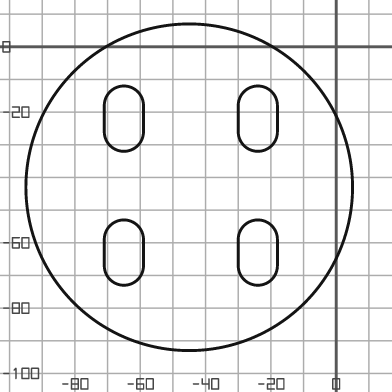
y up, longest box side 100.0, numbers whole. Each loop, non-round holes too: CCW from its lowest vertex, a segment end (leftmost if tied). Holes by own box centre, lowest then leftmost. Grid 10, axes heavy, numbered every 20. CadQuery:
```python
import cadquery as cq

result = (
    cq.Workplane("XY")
    .moveTo(-45.0, -43.0)
    .circle(50.0)
    .moveTo(-71.0, -67.0)
    .threePointArc((-65.0, -73.0), (-59.0, -67.0))
    .lineTo(-59.0, -59.0)
    .threePointArc((-65.0, -53.0), (-71.0, -59.0))
    .close()
    .moveTo(-30.0, -67.0)
    .threePointArc((-24.0, -73.0), (-18.0, -67.0))
    .lineTo(-18.0, -59.0)
    .threePointArc((-24.0, -53.0), (-30.0, -59.0))
    .close()
    .moveTo(-71.0, -26.0)
    .threePointArc((-65.0, -32.0), (-59.0, -26.0))
    .lineTo(-59.0, -18.0)
    .threePointArc((-65.0, -12.0), (-71.0, -18.0))
    .close()
    .moveTo(-30.0, -26.0)
    .threePointArc((-24.0, -32.0), (-18.0, -26.0))
    .lineTo(-18.0, -18.0)
    .threePointArc((-24.0, -12.0), (-30.0, -18.0))
    .close()
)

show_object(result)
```